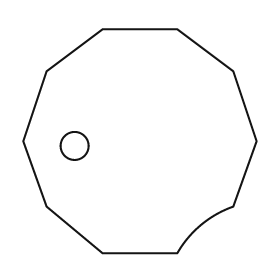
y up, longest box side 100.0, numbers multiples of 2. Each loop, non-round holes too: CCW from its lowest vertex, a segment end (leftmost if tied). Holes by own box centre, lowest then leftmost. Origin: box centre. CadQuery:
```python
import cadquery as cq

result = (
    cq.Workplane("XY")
    .moveTo(-16.0, -48.0)
    .lineTo(16.0, -48.0)
    .threePointArc((26.0, -36.0), (40.0, -28.0))
    .lineTo(50.0, 0.0)
    .lineTo(40.0, 30.0)
    .lineTo(16.0, 48.0)
    .lineTo(-16.0, 48.0)
    .lineTo(-40.0, 30.0)
    .lineTo(-50.0, 0.0)
    .lineTo(-40.0, -28.0)
    .close()
    .moveTo(-28.0, -2.0)
    .circle(6.0)
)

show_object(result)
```